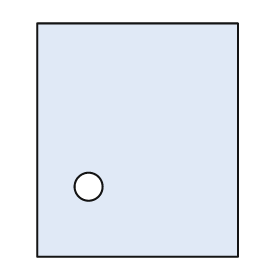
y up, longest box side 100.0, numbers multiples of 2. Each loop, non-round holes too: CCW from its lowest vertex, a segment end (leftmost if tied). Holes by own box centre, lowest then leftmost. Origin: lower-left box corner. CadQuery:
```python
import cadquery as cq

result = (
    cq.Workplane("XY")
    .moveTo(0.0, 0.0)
    .lineTo(86.0, 0.0)
    .lineTo(86.0, 100.0)
    .lineTo(0.0, 100.0)
    .close()
    .moveTo(22.0, 30.0)
    .circle(6.0)
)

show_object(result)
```